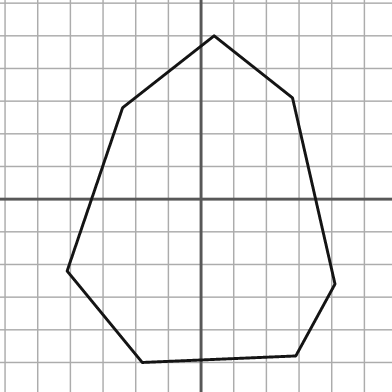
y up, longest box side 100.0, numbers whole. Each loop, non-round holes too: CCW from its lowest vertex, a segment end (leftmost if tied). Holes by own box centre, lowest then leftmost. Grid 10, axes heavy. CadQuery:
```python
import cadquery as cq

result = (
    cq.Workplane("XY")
    .moveTo(-18.0, -50.0)
    .lineTo(29.0, -48.0)
    .lineTo(41.0, -26.0)
    .lineTo(28.0, 31.0)
    .lineTo(4.0, 50.0)
    .lineTo(-24.0, 28.0)
    .lineTo(-41.0, -22.0)
    .close()
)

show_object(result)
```